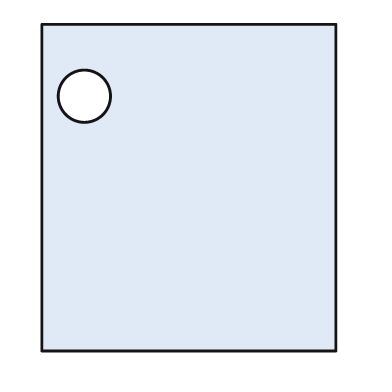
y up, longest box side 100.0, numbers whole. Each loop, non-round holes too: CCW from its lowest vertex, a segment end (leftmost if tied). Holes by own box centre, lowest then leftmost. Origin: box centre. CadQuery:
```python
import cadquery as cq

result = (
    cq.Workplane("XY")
    .moveTo(-45.0, -50.0)
    .lineTo(45.0, -50.0)
    .lineTo(45.0, 50.0)
    .lineTo(-45.0, 50.0)
    .close()
    .moveTo(-32.0, 28.0)
    .circle(8.0)
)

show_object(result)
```